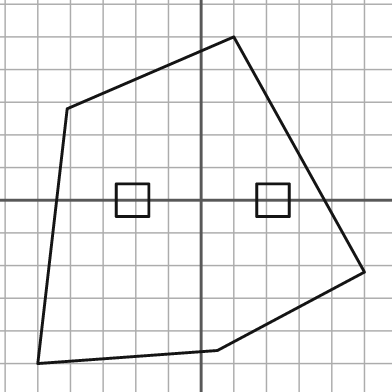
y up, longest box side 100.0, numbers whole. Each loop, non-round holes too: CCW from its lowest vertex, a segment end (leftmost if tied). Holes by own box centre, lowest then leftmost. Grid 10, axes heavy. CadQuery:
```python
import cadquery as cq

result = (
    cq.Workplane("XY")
    .moveTo(-50.0, -50.0)
    .lineTo(5.0, -46.0)
    .lineTo(50.0, -22.0)
    .lineTo(10.0, 50.0)
    .lineTo(-41.0, 28.0)
    .close()
    .moveTo(-26.0, -5.0)
    .lineTo(-16.0, -5.0)
    .lineTo(-16.0, 5.0)
    .lineTo(-26.0, 5.0)
    .close()
    .moveTo(17.0, -5.0)
    .lineTo(27.0, -5.0)
    .lineTo(27.0, 5.0)
    .lineTo(17.0, 5.0)
    .close()
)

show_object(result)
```